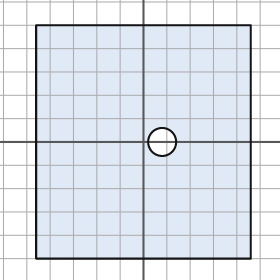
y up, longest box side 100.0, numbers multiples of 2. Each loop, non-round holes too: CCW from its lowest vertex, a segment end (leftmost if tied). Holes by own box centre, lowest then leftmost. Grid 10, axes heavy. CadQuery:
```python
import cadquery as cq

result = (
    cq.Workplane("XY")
    .moveTo(-46.0, -50.0)
    .lineTo(46.0, -50.0)
    .lineTo(46.0, 50.0)
    .lineTo(-46.0, 50.0)
    .close()
    .moveTo(8.0, 0.0)
    .circle(6.0)
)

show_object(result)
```